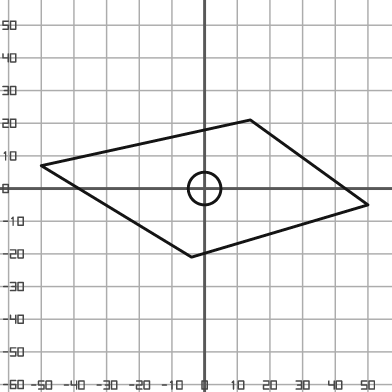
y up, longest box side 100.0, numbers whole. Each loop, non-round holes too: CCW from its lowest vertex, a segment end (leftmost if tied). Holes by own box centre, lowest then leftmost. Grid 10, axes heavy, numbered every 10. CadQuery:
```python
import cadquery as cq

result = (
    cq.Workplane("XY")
    .moveTo(-4.0, -21.0)
    .lineTo(50.0, -5.0)
    .lineTo(14.0, 21.0)
    .lineTo(-50.0, 7.0)
    .close()
    .moveTo(0.0, 0.0)
    .circle(5.0)
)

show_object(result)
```